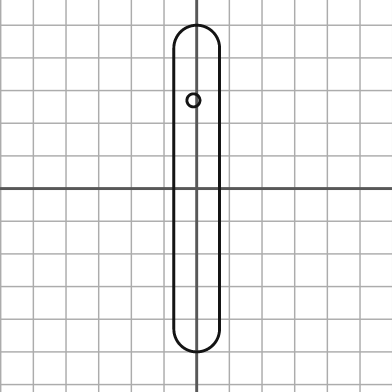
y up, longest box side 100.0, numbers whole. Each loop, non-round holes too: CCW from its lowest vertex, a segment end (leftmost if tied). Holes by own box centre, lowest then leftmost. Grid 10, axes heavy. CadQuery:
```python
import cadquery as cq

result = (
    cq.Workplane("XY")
    .moveTo(-7.0, -43.0)
    .threePointArc((0.0, -50.0), (7.0, -43.0))
    .lineTo(7.0, 43.0)
    .threePointArc((0.0, 50.0), (-7.0, 43.0))
    .close()
    .moveTo(-1.0, 27.0)
    .circle(2.0)
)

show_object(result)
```